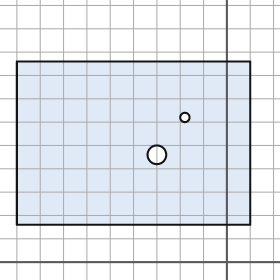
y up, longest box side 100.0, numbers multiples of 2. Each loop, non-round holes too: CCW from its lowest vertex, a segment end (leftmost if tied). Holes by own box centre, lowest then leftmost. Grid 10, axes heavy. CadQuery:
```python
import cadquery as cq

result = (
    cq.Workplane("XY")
    .moveTo(-90.0, 16.0)
    .lineTo(10.0, 16.0)
    .lineTo(10.0, 86.0)
    .lineTo(-90.0, 86.0)
    .close()
    .moveTo(-30.0, 46.0)
    .circle(4.0)
    .moveTo(-18.0, 62.0)
    .circle(2.0)
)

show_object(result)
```